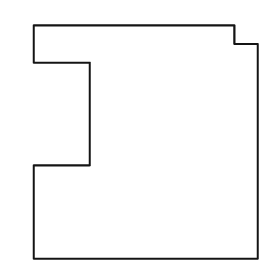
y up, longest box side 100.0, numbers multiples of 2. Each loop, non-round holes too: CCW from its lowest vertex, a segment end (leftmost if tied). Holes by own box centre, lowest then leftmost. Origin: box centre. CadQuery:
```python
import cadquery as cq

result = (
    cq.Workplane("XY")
    .moveTo(-48.0, -50.0)
    .lineTo(48.0, -50.0)
    .lineTo(48.0, 42.0)
    .lineTo(38.0, 42.0)
    .lineTo(38.0, 50.0)
    .lineTo(-48.0, 50.0)
    .lineTo(-48.0, 34.0)
    .lineTo(-24.0, 34.0)
    .lineTo(-24.0, -10.0)
    .lineTo(-48.0, -10.0)
    .close()
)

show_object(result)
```